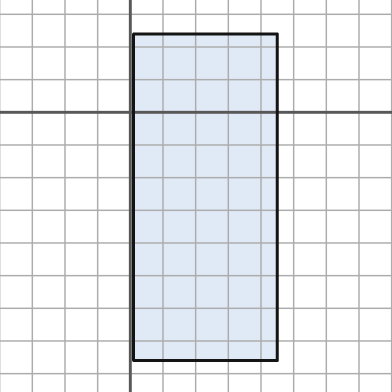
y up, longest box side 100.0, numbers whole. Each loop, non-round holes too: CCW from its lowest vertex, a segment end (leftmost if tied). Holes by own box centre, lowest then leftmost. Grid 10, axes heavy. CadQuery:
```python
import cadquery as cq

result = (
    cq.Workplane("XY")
    .moveTo(1.0, -76.0)
    .lineTo(45.0, -76.0)
    .lineTo(45.0, 24.0)
    .lineTo(1.0, 24.0)
    .close()
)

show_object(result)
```